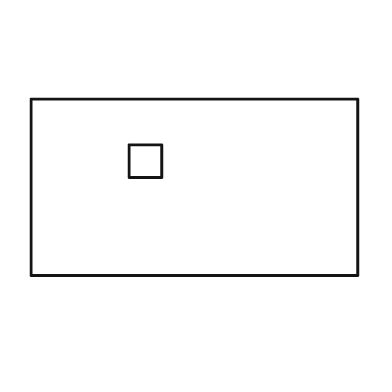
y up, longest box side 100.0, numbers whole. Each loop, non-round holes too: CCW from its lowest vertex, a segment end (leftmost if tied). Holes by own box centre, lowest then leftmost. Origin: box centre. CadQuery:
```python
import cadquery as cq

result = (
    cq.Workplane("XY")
    .moveTo(-50.0, -27.0)
    .lineTo(50.0, -27.0)
    .lineTo(50.0, 27.0)
    .lineTo(-50.0, 27.0)
    .close()
    .moveTo(-20.0, 3.0)
    .lineTo(-10.0, 3.0)
    .lineTo(-10.0, 13.0)
    .lineTo(-20.0, 13.0)
    .close()
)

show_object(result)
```